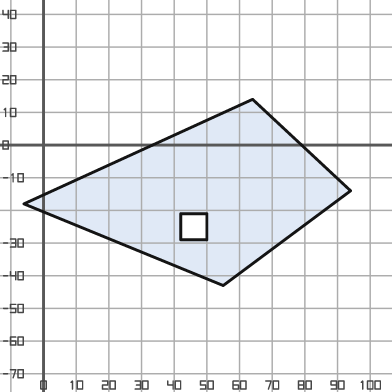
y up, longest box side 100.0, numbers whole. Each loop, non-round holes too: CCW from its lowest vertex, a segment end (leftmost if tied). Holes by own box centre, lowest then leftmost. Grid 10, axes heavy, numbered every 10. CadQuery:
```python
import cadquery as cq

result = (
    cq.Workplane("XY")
    .moveTo(55.0, -43.0)
    .lineTo(94.0, -14.0)
    .lineTo(64.0, 14.0)
    .lineTo(-6.0, -18.0)
    .close()
    .moveTo(42.0, -29.0)
    .lineTo(50.0, -29.0)
    .lineTo(50.0, -21.0)
    .lineTo(42.0, -21.0)
    .close()
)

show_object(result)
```